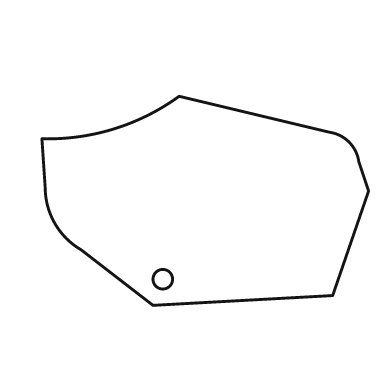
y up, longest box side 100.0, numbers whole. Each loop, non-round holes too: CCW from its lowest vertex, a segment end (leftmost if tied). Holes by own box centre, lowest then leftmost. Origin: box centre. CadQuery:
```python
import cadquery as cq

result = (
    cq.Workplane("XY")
    .moveTo(-16.0, -32.0)
    .lineTo(39.0, -29.0)
    .lineTo(50.0, 3.0)
    .lineTo(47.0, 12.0)
    .threePointArc((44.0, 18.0), (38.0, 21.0))
    .lineTo(-8.0, 32.0)
    .threePointArc((-28.0, 22.0), (-50.0, 19.0))
    .lineTo(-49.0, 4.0)
    .threePointArc((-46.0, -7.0), (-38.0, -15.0))
    .close()
    .moveTo(-13.0, -24.0)
    .circle(3.0)
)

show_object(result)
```